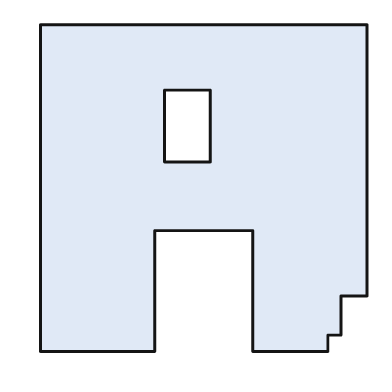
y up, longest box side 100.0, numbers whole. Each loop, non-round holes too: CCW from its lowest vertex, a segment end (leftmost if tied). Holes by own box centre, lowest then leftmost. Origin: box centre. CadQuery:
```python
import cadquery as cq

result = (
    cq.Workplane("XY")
    .moveTo(-50.0, -50.0)
    .lineTo(-15.0, -50.0)
    .lineTo(-15.0, -13.0)
    .lineTo(15.0, -13.0)
    .lineTo(15.0, -50.0)
    .lineTo(38.0, -50.0)
    .lineTo(38.0, -45.0)
    .lineTo(42.0, -45.0)
    .lineTo(42.0, -33.0)
    .lineTo(50.0, -33.0)
    .lineTo(50.0, 50.0)
    .lineTo(-50.0, 50.0)
    .close()
    .moveTo(-12.0, 8.0)
    .lineTo(2.0, 8.0)
    .lineTo(2.0, 30.0)
    .lineTo(-12.0, 30.0)
    .close()
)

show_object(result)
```